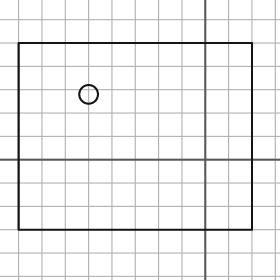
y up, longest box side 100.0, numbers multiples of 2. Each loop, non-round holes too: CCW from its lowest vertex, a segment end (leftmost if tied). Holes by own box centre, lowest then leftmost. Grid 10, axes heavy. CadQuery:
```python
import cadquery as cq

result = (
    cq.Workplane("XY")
    .moveTo(-80.0, -30.0)
    .lineTo(20.0, -30.0)
    .lineTo(20.0, 50.0)
    .lineTo(-80.0, 50.0)
    .close()
    .moveTo(-50.0, 28.0)
    .circle(4.0)
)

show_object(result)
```